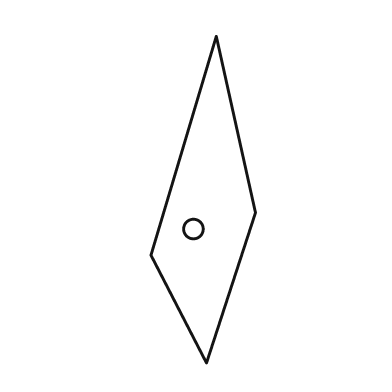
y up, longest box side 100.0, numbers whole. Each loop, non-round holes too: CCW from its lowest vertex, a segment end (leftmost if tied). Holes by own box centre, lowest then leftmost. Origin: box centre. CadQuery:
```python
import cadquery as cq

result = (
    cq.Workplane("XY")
    .moveTo(1.0, -50.0)
    .lineTo(16.0, -4.0)
    .lineTo(4.0, 50.0)
    .lineTo(-16.0, -17.0)
    .close()
    .moveTo(-3.0, -9.0)
    .circle(3.0)
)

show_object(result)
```